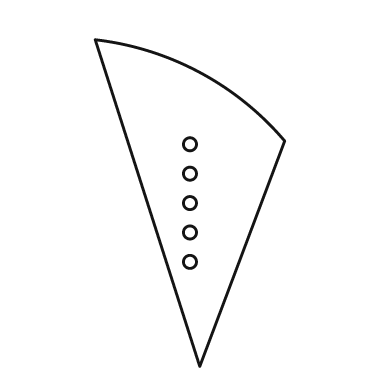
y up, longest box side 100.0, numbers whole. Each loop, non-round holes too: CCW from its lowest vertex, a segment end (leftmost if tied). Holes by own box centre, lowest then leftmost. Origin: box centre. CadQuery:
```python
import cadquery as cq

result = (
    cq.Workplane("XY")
    .moveTo(3.0, -50.0)
    .lineTo(29.0, 19.0)
    .threePointArc((3.0, 40.0), (-29.0, 50.0))
    .close()
    .moveTo(0.0, -18.0)
    .circle(2.0)
    .moveTo(0.0, -9.0)
    .circle(2.0)
    .moveTo(0.0, 0.0)
    .circle(2.0)
    .moveTo(0.0, 9.0)
    .circle(2.0)
    .moveTo(0.0, 18.0)
    .circle(2.0)
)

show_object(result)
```